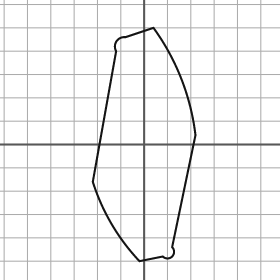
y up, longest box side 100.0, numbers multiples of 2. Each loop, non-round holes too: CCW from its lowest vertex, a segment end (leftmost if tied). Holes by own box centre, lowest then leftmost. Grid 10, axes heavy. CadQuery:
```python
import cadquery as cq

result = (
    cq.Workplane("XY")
    .moveTo(-2.0, -50.0)
    .lineTo(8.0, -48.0)
    .threePointArc((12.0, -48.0), (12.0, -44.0))
    .lineTo(22.0, 4.0)
    .threePointArc((16.0, 28.0), (4.0, 50.0))
    .lineTo(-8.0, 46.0)
    .threePointArc((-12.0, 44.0), (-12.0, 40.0))
    .lineTo(-22.0, -16.0)
    .threePointArc((-14.0, -34.0), (-2.0, -50.0))
    .close()
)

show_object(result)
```